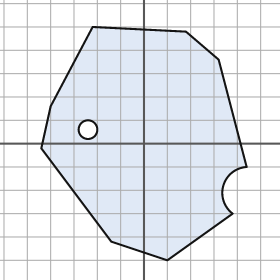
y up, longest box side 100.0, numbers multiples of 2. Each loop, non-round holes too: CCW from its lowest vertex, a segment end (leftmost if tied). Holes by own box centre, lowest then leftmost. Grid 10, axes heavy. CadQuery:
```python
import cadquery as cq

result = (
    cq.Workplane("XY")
    .moveTo(10.0, -50.0)
    .lineTo(38.0, -30.0)
    .threePointArc((34.0, -18.0), (44.0, -10.0))
    .lineTo(32.0, 36.0)
    .lineTo(18.0, 48.0)
    .lineTo(-22.0, 50.0)
    .lineTo(-40.0, 16.0)
    .lineTo(-44.0, -2.0)
    .lineTo(-14.0, -42.0)
    .close()
    .moveTo(-24.0, 6.0)
    .circle(4.0)
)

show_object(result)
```